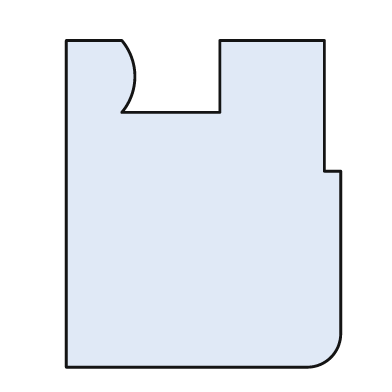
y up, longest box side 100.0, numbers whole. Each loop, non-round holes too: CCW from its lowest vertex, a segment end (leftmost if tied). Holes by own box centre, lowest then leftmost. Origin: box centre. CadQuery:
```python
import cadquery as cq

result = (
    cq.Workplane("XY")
    .moveTo(-42.0, -50.0)
    .lineTo(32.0, -50.0)
    .threePointArc((39.0, -47.0), (42.0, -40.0))
    .lineTo(42.0, 10.0)
    .lineTo(37.0, 10.0)
    .lineTo(37.0, 50.0)
    .lineTo(5.0, 50.0)
    .lineTo(5.0, 28.0)
    .lineTo(-25.0, 28.0)
    .threePointArc((-21.0, 39.0), (-25.0, 50.0))
    .lineTo(-42.0, 50.0)
    .close()
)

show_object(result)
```